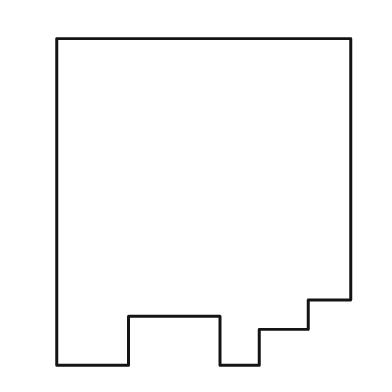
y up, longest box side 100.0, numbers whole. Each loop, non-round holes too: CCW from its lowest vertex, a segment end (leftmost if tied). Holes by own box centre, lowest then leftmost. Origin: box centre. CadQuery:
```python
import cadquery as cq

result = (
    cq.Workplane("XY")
    .moveTo(-45.0, -50.0)
    .lineTo(-23.0, -50.0)
    .lineTo(-23.0, -35.0)
    .lineTo(5.0, -35.0)
    .lineTo(5.0, -50.0)
    .lineTo(17.0, -50.0)
    .lineTo(17.0, -39.0)
    .lineTo(32.0, -39.0)
    .lineTo(32.0, -30.0)
    .lineTo(45.0, -30.0)
    .lineTo(45.0, 50.0)
    .lineTo(-45.0, 50.0)
    .close()
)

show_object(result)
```